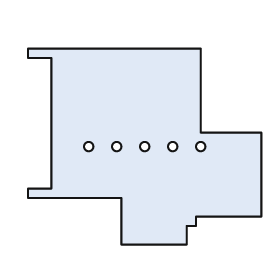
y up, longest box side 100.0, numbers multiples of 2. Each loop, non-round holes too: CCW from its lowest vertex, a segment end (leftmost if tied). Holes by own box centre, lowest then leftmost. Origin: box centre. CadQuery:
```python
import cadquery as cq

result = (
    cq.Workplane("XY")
    .moveTo(-10.0, -42.0)
    .lineTo(18.0, -42.0)
    .lineTo(18.0, -34.0)
    .lineTo(22.0, -34.0)
    .lineTo(22.0, -30.0)
    .lineTo(50.0, -30.0)
    .lineTo(50.0, 6.0)
    .lineTo(24.0, 6.0)
    .lineTo(24.0, 42.0)
    .lineTo(-50.0, 42.0)
    .lineTo(-50.0, 38.0)
    .lineTo(-40.0, 38.0)
    .lineTo(-40.0, -18.0)
    .lineTo(-50.0, -18.0)
    .lineTo(-50.0, -22.0)
    .lineTo(-10.0, -22.0)
    .close()
    .moveTo(-24.0, 0.0)
    .circle(2.0)
    .moveTo(-12.0, 0.0)
    .circle(2.0)
    .moveTo(0.0, 0.0)
    .circle(2.0)
    .moveTo(12.0, 0.0)
    .circle(2.0)
    .moveTo(24.0, 0.0)
    .circle(2.0)
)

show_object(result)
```